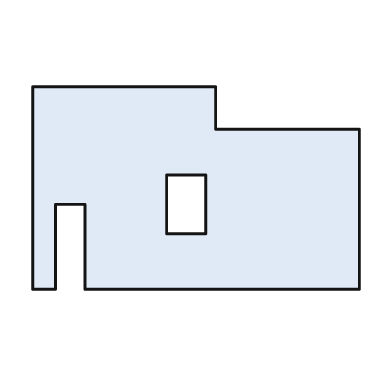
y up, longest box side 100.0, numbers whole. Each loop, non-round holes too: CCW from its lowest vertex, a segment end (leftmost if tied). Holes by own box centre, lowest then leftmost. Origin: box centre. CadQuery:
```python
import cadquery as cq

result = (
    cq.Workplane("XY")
    .moveTo(-50.0, -31.0)
    .lineTo(-43.0, -31.0)
    .lineTo(-43.0, -5.0)
    .lineTo(-34.0, -5.0)
    .lineTo(-34.0, -31.0)
    .lineTo(50.0, -31.0)
    .lineTo(50.0, 18.0)
    .lineTo(6.0, 18.0)
    .lineTo(6.0, 31.0)
    .lineTo(-50.0, 31.0)
    .close()
    .moveTo(-9.0, -14.0)
    .lineTo(3.0, -14.0)
    .lineTo(3.0, 4.0)
    .lineTo(-9.0, 4.0)
    .close()
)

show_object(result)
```